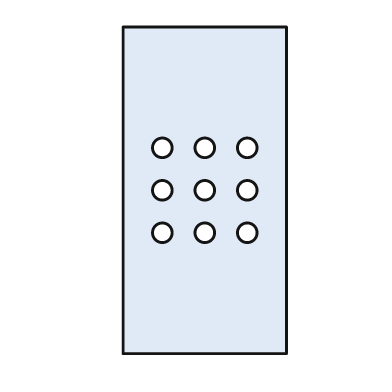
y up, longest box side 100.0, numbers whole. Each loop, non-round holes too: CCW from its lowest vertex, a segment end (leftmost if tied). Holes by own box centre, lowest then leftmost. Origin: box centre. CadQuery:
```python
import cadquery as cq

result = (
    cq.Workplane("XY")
    .moveTo(-25.0, -50.0)
    .lineTo(25.0, -50.0)
    .lineTo(25.0, 50.0)
    .lineTo(-25.0, 50.0)
    .close()
    .moveTo(-13.0, -13.0)
    .circle(3.0)
    .moveTo(0.0, -13.0)
    .circle(3.0)
    .moveTo(13.0, -13.0)
    .circle(3.0)
    .moveTo(-13.0, 0.0)
    .circle(3.0)
    .moveTo(0.0, 0.0)
    .circle(3.0)
    .moveTo(13.0, 0.0)
    .circle(3.0)
    .moveTo(-13.0, 13.0)
    .circle(3.0)
    .moveTo(0.0, 13.0)
    .circle(3.0)
    .moveTo(13.0, 13.0)
    .circle(3.0)
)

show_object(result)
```